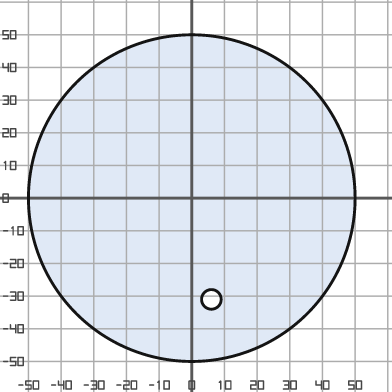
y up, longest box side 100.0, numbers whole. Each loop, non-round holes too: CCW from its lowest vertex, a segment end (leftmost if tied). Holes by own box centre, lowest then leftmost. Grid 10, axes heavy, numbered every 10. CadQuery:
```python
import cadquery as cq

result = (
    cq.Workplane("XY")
    .moveTo(0.0, 0.0)
    .circle(50.0)
    .moveTo(6.0, -31.0)
    .circle(3.0)
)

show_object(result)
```